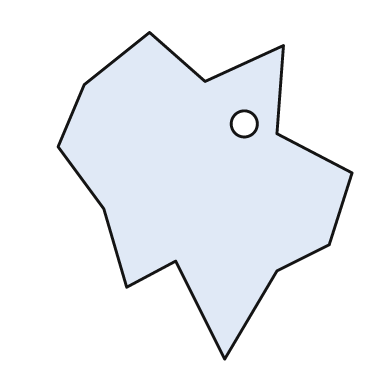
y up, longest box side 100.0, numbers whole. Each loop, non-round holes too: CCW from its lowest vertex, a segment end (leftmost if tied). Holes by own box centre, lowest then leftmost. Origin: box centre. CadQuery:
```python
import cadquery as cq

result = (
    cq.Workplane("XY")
    .moveTo(6.0, -50.0)
    .lineTo(22.0, -23.0)
    .lineTo(38.0, -15.0)
    .lineTo(45.0, 7.0)
    .lineTo(22.0, 19.0)
    .lineTo(24.0, 46.0)
    .lineTo(0.0, 35.0)
    .lineTo(-17.0, 50.0)
    .lineTo(-37.0, 34.0)
    .lineTo(-45.0, 15.0)
    .lineTo(-31.0, -4.0)
    .lineTo(-24.0, -28.0)
    .lineTo(-9.0, -20.0)
    .close()
    .moveTo(12.0, 22.0)
    .circle(4.0)
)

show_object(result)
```